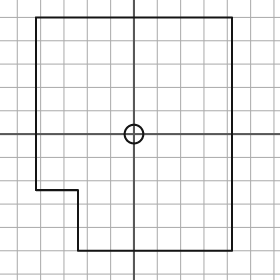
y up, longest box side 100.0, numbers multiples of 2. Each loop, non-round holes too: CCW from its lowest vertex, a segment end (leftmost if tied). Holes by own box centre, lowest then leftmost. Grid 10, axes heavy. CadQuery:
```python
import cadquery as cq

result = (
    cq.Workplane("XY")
    .moveTo(-24.0, -50.0)
    .lineTo(42.0, -50.0)
    .lineTo(42.0, 50.0)
    .lineTo(-42.0, 50.0)
    .lineTo(-42.0, -24.0)
    .lineTo(-24.0, -24.0)
    .close()
    .moveTo(0.0, 0.0)
    .circle(4.0)
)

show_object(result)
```